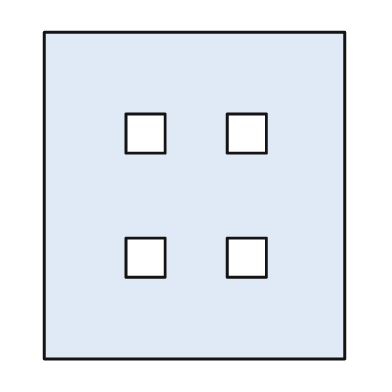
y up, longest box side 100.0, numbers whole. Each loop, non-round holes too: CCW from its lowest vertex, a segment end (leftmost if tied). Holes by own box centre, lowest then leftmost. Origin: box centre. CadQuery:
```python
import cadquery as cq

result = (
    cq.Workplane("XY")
    .moveTo(-46.0, -50.0)
    .lineTo(46.0, -50.0)
    .lineTo(46.0, 50.0)
    .lineTo(-46.0, 50.0)
    .close()
    .moveTo(-21.0, -25.0)
    .lineTo(-9.0, -25.0)
    .lineTo(-9.0, -13.0)
    .lineTo(-21.0, -13.0)
    .close()
    .moveTo(10.0, -25.0)
    .lineTo(22.0, -25.0)
    .lineTo(22.0, -13.0)
    .lineTo(10.0, -13.0)
    .close()
    .moveTo(-21.0, 13.0)
    .lineTo(-9.0, 13.0)
    .lineTo(-9.0, 25.0)
    .lineTo(-21.0, 25.0)
    .close()
    .moveTo(10.0, 13.0)
    .lineTo(22.0, 13.0)
    .lineTo(22.0, 25.0)
    .lineTo(10.0, 25.0)
    .close()
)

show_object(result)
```